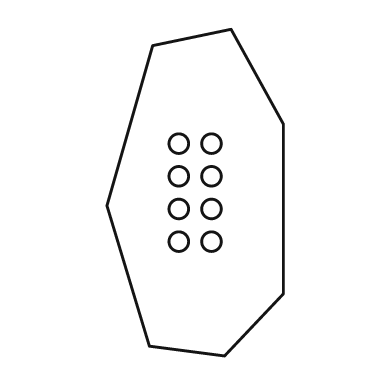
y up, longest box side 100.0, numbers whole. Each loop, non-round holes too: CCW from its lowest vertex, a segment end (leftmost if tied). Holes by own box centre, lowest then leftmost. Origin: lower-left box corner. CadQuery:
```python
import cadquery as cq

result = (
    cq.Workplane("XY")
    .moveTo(36.0, 0.0)
    .lineTo(54.0, 19.0)
    .lineTo(54.0, 71.0)
    .lineTo(38.0, 100.0)
    .lineTo(14.0, 95.0)
    .lineTo(0.0, 46.0)
    .lineTo(13.0, 3.0)
    .close()
    .moveTo(22.0, 35.0)
    .circle(3.0)
    .moveTo(32.0, 35.0)
    .circle(3.0)
    .moveTo(22.0, 45.0)
    .circle(3.0)
    .moveTo(32.0, 45.0)
    .circle(3.0)
    .moveTo(22.0, 55.0)
    .circle(3.0)
    .moveTo(32.0, 55.0)
    .circle(3.0)
    .moveTo(22.0, 65.0)
    .circle(3.0)
    .moveTo(32.0, 65.0)
    .circle(3.0)
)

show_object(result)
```